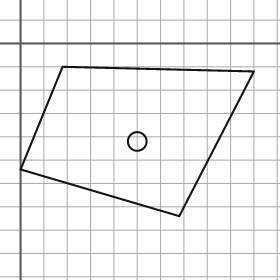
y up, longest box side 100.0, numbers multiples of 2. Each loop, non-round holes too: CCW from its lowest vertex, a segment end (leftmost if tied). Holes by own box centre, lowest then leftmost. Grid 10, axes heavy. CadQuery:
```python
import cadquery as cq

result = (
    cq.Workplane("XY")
    .moveTo(68.0, -74.0)
    .lineTo(100.0, -12.0)
    .lineTo(18.0, -10.0)
    .lineTo(0.0, -54.0)
    .close()
    .moveTo(50.0, -42.0)
    .circle(4.0)
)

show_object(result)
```